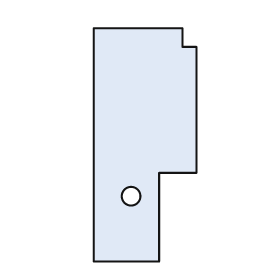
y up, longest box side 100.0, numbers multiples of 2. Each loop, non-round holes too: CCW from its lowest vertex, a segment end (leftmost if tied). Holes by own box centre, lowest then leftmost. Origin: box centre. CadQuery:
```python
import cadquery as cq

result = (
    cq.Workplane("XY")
    .moveTo(-22.0, -50.0)
    .lineTo(6.0, -50.0)
    .lineTo(6.0, -12.0)
    .lineTo(22.0, -12.0)
    .lineTo(22.0, 42.0)
    .lineTo(16.0, 42.0)
    .lineTo(16.0, 50.0)
    .lineTo(-22.0, 50.0)
    .close()
    .moveTo(-6.0, -22.0)
    .circle(4.0)
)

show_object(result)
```